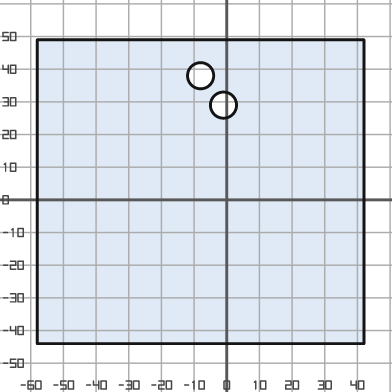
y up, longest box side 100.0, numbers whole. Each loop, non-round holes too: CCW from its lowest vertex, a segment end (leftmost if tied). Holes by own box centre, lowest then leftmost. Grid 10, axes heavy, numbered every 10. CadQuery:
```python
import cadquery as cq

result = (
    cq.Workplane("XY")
    .moveTo(-58.0, -44.0)
    .lineTo(42.0, -44.0)
    .lineTo(42.0, 49.0)
    .lineTo(-58.0, 49.0)
    .close()
    .moveTo(-1.0, 29.0)
    .circle(4.0)
    .moveTo(-8.0, 38.0)
    .circle(4.0)
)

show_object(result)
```